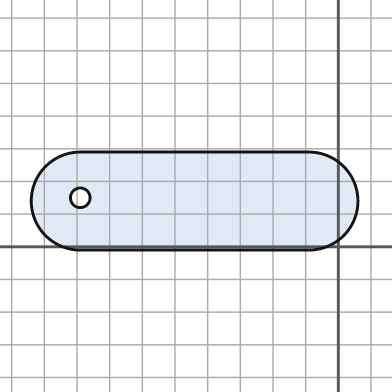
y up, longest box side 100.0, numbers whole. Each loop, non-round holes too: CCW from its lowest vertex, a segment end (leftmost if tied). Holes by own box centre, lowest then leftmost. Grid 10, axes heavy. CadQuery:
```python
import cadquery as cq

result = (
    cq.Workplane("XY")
    .moveTo(-79.0, -1.0)
    .lineTo(-9.0, -1.0)
    .threePointArc((6.0, 14.0), (-9.0, 29.0))
    .lineTo(-79.0, 29.0)
    .threePointArc((-94.0, 14.0), (-79.0, -1.0))
    .close()
    .moveTo(-79.0, 15.0)
    .circle(3.0)
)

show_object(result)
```